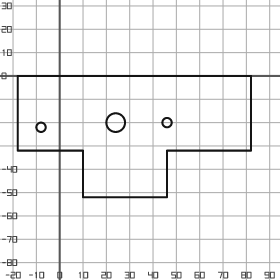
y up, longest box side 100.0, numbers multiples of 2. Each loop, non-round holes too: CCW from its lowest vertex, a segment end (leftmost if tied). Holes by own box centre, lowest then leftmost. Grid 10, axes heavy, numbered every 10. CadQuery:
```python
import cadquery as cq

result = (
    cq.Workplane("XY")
    .moveTo(10.0, -52.0)
    .lineTo(46.0, -52.0)
    .lineTo(46.0, -32.0)
    .lineTo(82.0, -32.0)
    .lineTo(82.0, 0.0)
    .lineTo(-18.0, 0.0)
    .lineTo(-18.0, -32.0)
    .lineTo(10.0, -32.0)
    .close()
    .moveTo(-8.0, -22.0)
    .circle(2.0)
    .moveTo(24.0, -20.0)
    .circle(4.0)
    .moveTo(46.0, -20.0)
    .circle(2.0)
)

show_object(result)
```